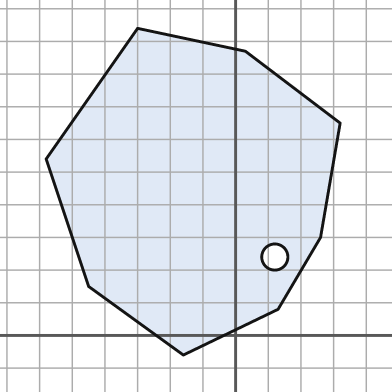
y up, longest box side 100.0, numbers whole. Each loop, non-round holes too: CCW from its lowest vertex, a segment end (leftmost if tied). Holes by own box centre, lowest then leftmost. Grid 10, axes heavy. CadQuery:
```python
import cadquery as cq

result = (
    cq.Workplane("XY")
    .moveTo(-16.0, -6.0)
    .lineTo(13.0, 8.0)
    .lineTo(26.0, 30.0)
    .lineTo(32.0, 65.0)
    .lineTo(3.0, 87.0)
    .lineTo(-30.0, 94.0)
    .lineTo(-58.0, 54.0)
    .lineTo(-45.0, 15.0)
    .close()
    .moveTo(12.0, 24.0)
    .circle(4.0)
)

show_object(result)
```